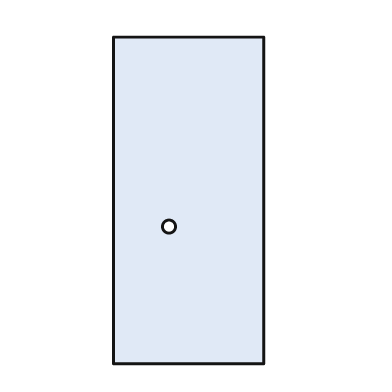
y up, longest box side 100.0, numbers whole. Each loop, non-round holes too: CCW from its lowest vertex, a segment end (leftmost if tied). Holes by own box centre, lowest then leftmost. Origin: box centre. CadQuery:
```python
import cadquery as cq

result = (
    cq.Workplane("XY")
    .moveTo(-23.0, -50.0)
    .lineTo(23.0, -50.0)
    .lineTo(23.0, 50.0)
    .lineTo(-23.0, 50.0)
    .close()
    .moveTo(-6.0, -8.0)
    .circle(2.0)
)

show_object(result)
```